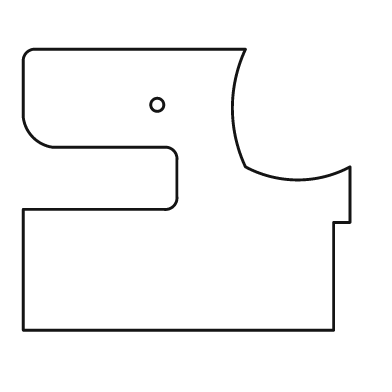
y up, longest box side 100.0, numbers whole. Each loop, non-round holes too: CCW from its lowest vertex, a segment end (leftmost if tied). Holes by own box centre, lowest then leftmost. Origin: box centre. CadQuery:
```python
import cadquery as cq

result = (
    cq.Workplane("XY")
    .moveTo(-50.0, -43.0)
    .lineTo(45.0, -43.0)
    .lineTo(45.0, -10.0)
    .lineTo(50.0, -10.0)
    .lineTo(50.0, 7.0)
    .threePointArc((34.0, 3.0), (18.0, 7.0))
    .threePointArc((14.0, 25.0), (18.0, 43.0))
    .lineTo(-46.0, 43.0)
    .threePointArc((-49.0, 42.0), (-50.0, 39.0))
    .lineTo(-50.0, 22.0)
    .threePointArc((-47.0, 16.0), (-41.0, 13.0))
    .lineTo(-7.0, 13.0)
    .threePointArc((-4.0, 12.0), (-3.0, 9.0))
    .lineTo(-3.0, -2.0)
    .threePointArc((-4.0, -5.0), (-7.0, -6.0))
    .lineTo(-50.0, -6.0)
    .close()
    .moveTo(-9.0, 26.0)
    .circle(2.0)
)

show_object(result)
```